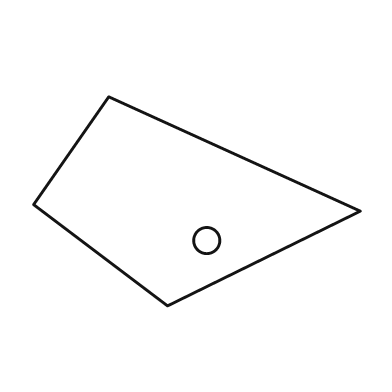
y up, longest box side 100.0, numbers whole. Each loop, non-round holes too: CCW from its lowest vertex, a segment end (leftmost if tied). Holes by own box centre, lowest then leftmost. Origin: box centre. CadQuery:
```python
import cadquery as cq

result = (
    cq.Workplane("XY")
    .moveTo(-9.0, -32.0)
    .lineTo(50.0, -3.0)
    .lineTo(-27.0, 32.0)
    .lineTo(-50.0, -1.0)
    .close()
    .moveTo(3.0, -12.0)
    .circle(4.0)
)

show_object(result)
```